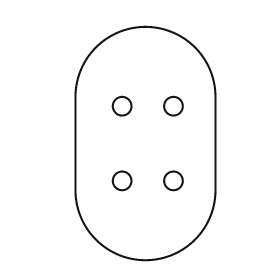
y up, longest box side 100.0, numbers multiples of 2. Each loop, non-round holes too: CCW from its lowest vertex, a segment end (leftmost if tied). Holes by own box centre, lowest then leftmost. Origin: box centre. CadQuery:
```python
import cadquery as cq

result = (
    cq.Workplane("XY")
    .moveTo(-30.0, -20.0)
    .threePointArc((0.0, -50.0), (30.0, -20.0))
    .lineTo(30.0, 20.0)
    .threePointArc((0.0, 50.0), (-30.0, 20.0))
    .close()
    .moveTo(-10.0, -16.0)
    .circle(4.0)
    .moveTo(12.0, -16.0)
    .circle(4.0)
    .moveTo(-10.0, 16.0)
    .circle(4.0)
    .moveTo(12.0, 16.0)
    .circle(4.0)
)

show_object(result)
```